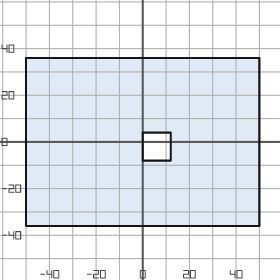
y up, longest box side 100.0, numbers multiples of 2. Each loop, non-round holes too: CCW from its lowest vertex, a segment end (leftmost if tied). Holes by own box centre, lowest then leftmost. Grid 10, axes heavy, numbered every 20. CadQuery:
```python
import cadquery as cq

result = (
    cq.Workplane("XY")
    .moveTo(-50.0, -36.0)
    .lineTo(50.0, -36.0)
    .lineTo(50.0, 36.0)
    .lineTo(-50.0, 36.0)
    .close()
    .moveTo(0.0, -8.0)
    .lineTo(12.0, -8.0)
    .lineTo(12.0, 4.0)
    .lineTo(0.0, 4.0)
    .close()
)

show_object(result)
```